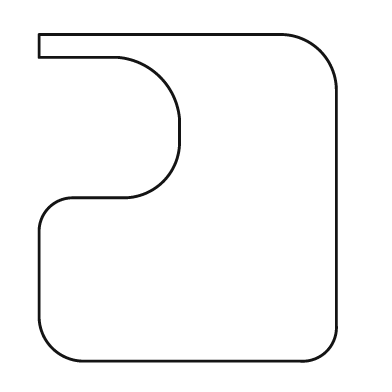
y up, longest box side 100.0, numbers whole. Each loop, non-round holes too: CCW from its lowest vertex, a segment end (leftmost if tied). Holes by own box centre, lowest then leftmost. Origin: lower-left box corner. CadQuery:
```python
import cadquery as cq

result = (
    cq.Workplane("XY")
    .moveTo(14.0, 0.0)
    .lineTo(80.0, 0.0)
    .threePointArc((88.0, 3.0), (91.0, 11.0))
    .lineTo(91.0, 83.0)
    .threePointArc((86.0, 95.0), (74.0, 100.0))
    .lineTo(0.0, 100.0)
    .lineTo(0.0, 93.0)
    .lineTo(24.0, 93.0)
    .threePointArc((37.0, 87.0), (43.0, 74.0))
    .lineTo(43.0, 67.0)
    .threePointArc((38.0, 55.0), (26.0, 50.0))
    .lineTo(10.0, 50.0)
    .threePointArc((3.0, 47.0), (0.0, 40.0))
    .lineTo(0.0, 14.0)
    .threePointArc((4.0, 4.0), (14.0, 0.0))
    .close()
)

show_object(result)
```